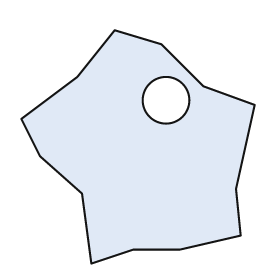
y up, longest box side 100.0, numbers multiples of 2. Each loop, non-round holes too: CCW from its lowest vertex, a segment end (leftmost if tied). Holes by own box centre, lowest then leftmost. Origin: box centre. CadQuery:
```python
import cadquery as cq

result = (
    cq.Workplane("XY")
    .moveTo(-20.0, -50.0)
    .lineTo(-2.0, -44.0)
    .lineTo(18.0, -44.0)
    .lineTo(44.0, -38.0)
    .lineTo(42.0, -18.0)
    .lineTo(50.0, 18.0)
    .lineTo(28.0, 26.0)
    .lineTo(10.0, 44.0)
    .lineTo(-10.0, 50.0)
    .lineTo(-26.0, 30.0)
    .lineTo(-50.0, 12.0)
    .lineTo(-42.0, -4.0)
    .lineTo(-24.0, -20.0)
    .close()
    .moveTo(12.0, 20.0)
    .circle(10.0)
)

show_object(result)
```